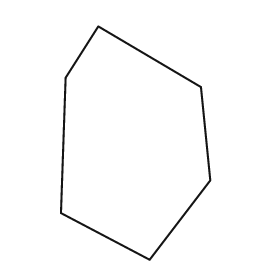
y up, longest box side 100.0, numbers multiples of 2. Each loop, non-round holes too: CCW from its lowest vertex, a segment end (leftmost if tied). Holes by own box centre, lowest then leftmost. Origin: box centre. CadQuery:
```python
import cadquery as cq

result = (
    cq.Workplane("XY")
    .moveTo(6.0, -50.0)
    .lineTo(32.0, -16.0)
    .lineTo(28.0, 24.0)
    .lineTo(-16.0, 50.0)
    .lineTo(-30.0, 28.0)
    .lineTo(-32.0, -30.0)
    .close()
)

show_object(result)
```